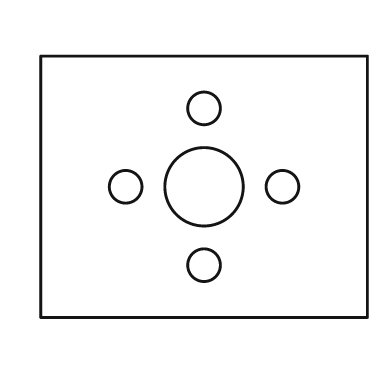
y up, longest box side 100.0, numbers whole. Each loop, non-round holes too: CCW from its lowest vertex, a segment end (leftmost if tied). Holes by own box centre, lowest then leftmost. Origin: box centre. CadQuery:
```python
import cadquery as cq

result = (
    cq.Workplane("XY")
    .moveTo(-50.0, -40.0)
    .lineTo(50.0, -40.0)
    .lineTo(50.0, 40.0)
    .lineTo(-50.0, 40.0)
    .close()
    .moveTo(0.0, -24.0)
    .circle(5.0)
    .moveTo(-24.0, 0.0)
    .circle(5.0)
    .moveTo(0.0, 0.0)
    .circle(12.0)
    .moveTo(24.0, 0.0)
    .circle(5.0)
    .moveTo(0.0, 24.0)
    .circle(5.0)
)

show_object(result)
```